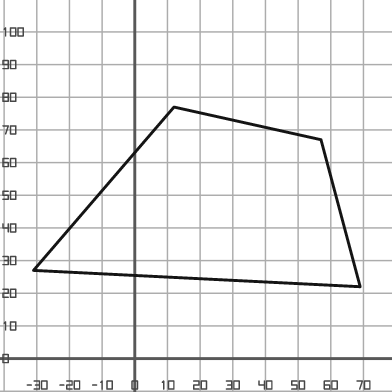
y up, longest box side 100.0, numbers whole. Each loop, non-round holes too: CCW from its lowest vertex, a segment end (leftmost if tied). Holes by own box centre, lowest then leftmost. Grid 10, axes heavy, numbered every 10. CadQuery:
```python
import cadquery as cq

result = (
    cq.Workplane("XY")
    .moveTo(69.0, 22.0)
    .lineTo(57.0, 67.0)
    .lineTo(12.0, 77.0)
    .lineTo(-31.0, 27.0)
    .close()
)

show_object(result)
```